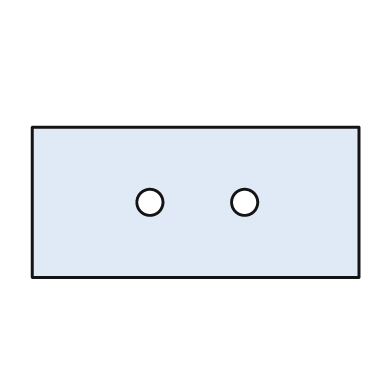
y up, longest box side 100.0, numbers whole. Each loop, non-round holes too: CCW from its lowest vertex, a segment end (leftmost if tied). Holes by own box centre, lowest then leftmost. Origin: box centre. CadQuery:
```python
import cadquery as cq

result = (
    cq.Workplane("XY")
    .moveTo(-50.0, -23.0)
    .lineTo(50.0, -23.0)
    .lineTo(50.0, 23.0)
    .lineTo(-50.0, 23.0)
    .close()
    .moveTo(-14.0, 0.0)
    .circle(4.0)
    .moveTo(15.0, 0.0)
    .circle(4.0)
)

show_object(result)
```